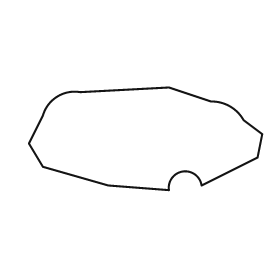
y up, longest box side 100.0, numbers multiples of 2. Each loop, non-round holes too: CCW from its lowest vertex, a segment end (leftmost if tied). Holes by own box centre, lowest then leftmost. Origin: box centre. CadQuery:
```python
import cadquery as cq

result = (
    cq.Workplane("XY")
    .moveTo(10.0, -22.0)
    .threePointArc((16.0, -14.0), (24.0, -20.0))
    .lineTo(48.0, -8.0)
    .lineTo(50.0, 2.0)
    .lineTo(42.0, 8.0)
    .threePointArc((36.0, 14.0), (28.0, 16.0))
    .lineTo(10.0, 22.0)
    .lineTo(-28.0, 20.0)
    .threePointArc((-38.0, 18.0), (-44.0, 10.0))
    .lineTo(-50.0, -2.0)
    .lineTo(-44.0, -12.0)
    .lineTo(-16.0, -20.0)
    .close()
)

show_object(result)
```